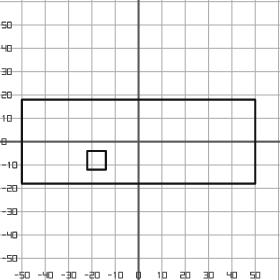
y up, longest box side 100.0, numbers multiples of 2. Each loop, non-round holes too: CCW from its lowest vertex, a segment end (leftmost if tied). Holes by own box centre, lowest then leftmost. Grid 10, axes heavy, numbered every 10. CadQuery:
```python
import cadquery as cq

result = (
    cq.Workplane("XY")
    .moveTo(-50.0, -18.0)
    .lineTo(50.0, -18.0)
    .lineTo(50.0, 18.0)
    .lineTo(-50.0, 18.0)
    .close()
    .moveTo(-22.0, -12.0)
    .lineTo(-14.0, -12.0)
    .lineTo(-14.0, -4.0)
    .lineTo(-22.0, -4.0)
    .close()
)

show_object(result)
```